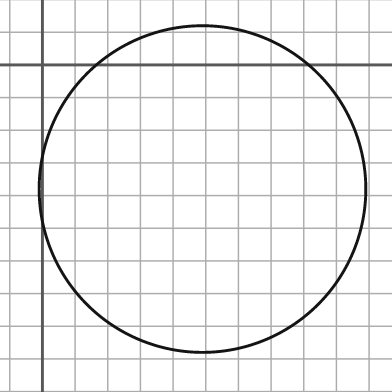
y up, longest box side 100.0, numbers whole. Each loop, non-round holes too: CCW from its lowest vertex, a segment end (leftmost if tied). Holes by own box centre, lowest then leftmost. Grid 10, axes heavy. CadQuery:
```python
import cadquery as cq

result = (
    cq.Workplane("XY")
    .moveTo(49.0, -38.0)
    .circle(50.0)
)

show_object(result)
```